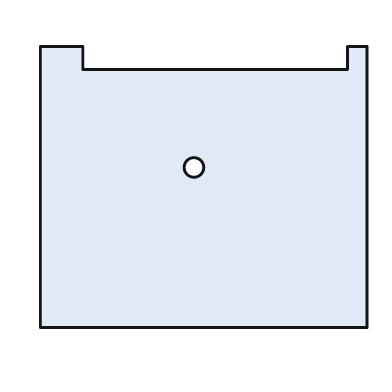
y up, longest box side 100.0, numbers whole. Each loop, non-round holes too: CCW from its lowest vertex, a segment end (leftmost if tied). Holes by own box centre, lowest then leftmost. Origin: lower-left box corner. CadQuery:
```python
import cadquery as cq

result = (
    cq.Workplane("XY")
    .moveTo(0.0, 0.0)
    .lineTo(100.0, 0.0)
    .lineTo(100.0, 86.0)
    .lineTo(94.0, 86.0)
    .lineTo(94.0, 79.0)
    .lineTo(13.0, 79.0)
    .lineTo(13.0, 86.0)
    .lineTo(0.0, 86.0)
    .close()
    .moveTo(47.0, 49.0)
    .circle(3.0)
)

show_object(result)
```